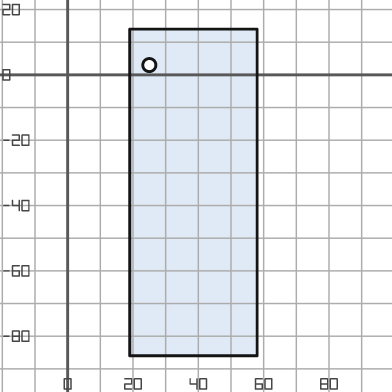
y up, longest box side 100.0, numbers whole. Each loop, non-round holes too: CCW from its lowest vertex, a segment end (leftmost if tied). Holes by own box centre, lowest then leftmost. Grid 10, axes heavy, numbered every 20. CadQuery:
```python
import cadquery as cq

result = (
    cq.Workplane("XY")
    .moveTo(19.0, -86.0)
    .lineTo(58.0, -86.0)
    .lineTo(58.0, 14.0)
    .lineTo(19.0, 14.0)
    .close()
    .moveTo(25.0, 3.0)
    .circle(2.0)
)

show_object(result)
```